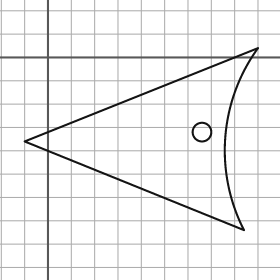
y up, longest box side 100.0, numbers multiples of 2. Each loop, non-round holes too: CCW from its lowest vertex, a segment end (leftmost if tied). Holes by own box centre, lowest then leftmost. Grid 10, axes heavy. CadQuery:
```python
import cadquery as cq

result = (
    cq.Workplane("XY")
    .moveTo(84.0, -74.0)
    .threePointArc((76.0, -34.0), (90.0, 4.0))
    .lineTo(-10.0, -36.0)
    .close()
    .moveTo(66.0, -32.0)
    .circle(4.0)
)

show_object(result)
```